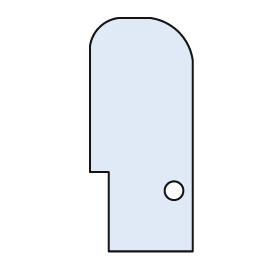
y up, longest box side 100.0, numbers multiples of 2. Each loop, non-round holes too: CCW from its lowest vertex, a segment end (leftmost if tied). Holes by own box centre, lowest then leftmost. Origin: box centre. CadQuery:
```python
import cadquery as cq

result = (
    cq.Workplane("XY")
    .moveTo(-14.0, -50.0)
    .lineTo(22.0, -50.0)
    .lineTo(22.0, 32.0)
    .threePointArc((16.0, 44.0), (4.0, 50.0))
    .lineTo(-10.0, 50.0)
    .threePointArc((-18.0, 46.0), (-22.0, 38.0))
    .lineTo(-22.0, -16.0)
    .lineTo(-14.0, -16.0)
    .close()
    .moveTo(14.0, -24.0)
    .circle(4.0)
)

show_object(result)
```